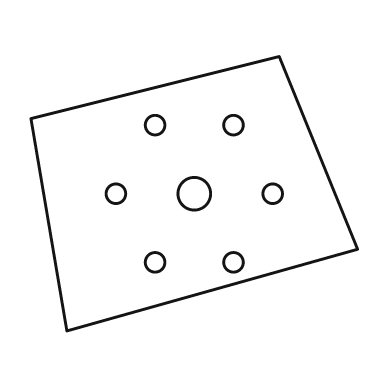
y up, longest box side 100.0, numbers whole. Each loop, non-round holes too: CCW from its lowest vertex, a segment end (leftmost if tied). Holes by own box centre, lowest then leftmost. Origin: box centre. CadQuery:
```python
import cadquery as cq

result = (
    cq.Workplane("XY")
    .moveTo(-39.0, -42.0)
    .lineTo(50.0, -17.0)
    .lineTo(26.0, 42.0)
    .lineTo(-50.0, 23.0)
    .close()
    .moveTo(-12.0, -21.0)
    .circle(3.0)
    .moveTo(12.0, -21.0)
    .circle(3.0)
    .moveTo(-24.0, 0.0)
    .circle(3.0)
    .moveTo(0.0, 0.0)
    .circle(5.0)
    .moveTo(24.0, 0.0)
    .circle(3.0)
    .moveTo(-12.0, 21.0)
    .circle(3.0)
    .moveTo(12.0, 21.0)
    .circle(3.0)
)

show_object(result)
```